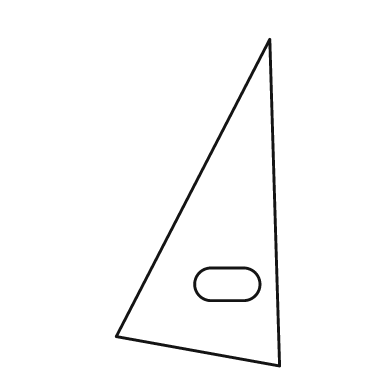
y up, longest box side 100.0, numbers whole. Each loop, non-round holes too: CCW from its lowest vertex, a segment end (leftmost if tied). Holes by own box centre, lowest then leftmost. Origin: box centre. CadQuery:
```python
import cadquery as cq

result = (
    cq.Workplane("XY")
    .moveTo(25.0, -50.0)
    .lineTo(22.0, 50.0)
    .lineTo(-25.0, -41.0)
    .close()
    .moveTo(4.0, -30.0)
    .lineTo(14.0, -30.0)
    .threePointArc((19.0, -25.0), (14.0, -20.0))
    .lineTo(4.0, -20.0)
    .threePointArc((-1.0, -25.0), (4.0, -30.0))
    .close()
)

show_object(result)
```